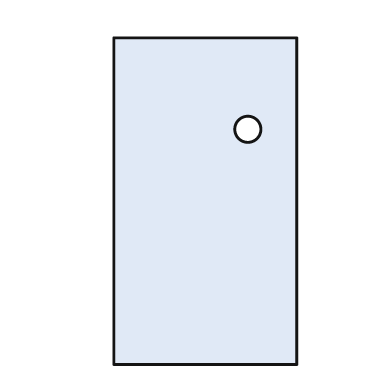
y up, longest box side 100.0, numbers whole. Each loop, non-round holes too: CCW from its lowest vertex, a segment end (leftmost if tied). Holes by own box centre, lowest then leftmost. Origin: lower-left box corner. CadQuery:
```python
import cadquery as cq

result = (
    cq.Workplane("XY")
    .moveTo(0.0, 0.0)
    .lineTo(56.0, 0.0)
    .lineTo(56.0, 100.0)
    .lineTo(0.0, 100.0)
    .close()
    .moveTo(41.0, 72.0)
    .circle(4.0)
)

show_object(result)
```